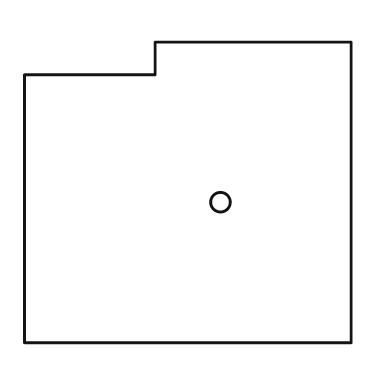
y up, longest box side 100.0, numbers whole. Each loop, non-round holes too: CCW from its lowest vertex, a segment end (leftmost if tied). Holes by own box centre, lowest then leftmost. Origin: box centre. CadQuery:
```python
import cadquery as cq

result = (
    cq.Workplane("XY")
    .moveTo(-50.0, -46.0)
    .lineTo(50.0, -46.0)
    .lineTo(50.0, 46.0)
    .lineTo(-10.0, 46.0)
    .lineTo(-10.0, 36.0)
    .lineTo(-50.0, 36.0)
    .close()
    .moveTo(10.0, -3.0)
    .circle(3.0)
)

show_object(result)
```